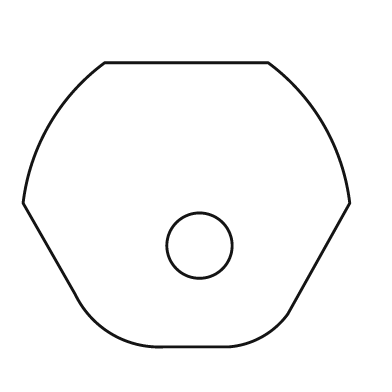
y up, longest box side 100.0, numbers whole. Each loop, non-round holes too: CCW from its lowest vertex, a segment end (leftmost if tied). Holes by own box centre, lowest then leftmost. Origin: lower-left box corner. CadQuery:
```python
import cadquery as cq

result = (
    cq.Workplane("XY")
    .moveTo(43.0, 0.0)
    .lineTo(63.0, 0.0)
    .threePointArc((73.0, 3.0), (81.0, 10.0))
    .lineTo(100.0, 44.0)
    .threePointArc((92.0, 68.0), (75.0, 87.0))
    .lineTo(25.0, 87.0)
    .threePointArc((8.0, 68.0), (0.0, 44.0))
    .lineTo(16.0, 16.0)
    .threePointArc((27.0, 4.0), (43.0, 0.0))
    .close()
    .moveTo(54.0, 31.0)
    .circle(10.0)
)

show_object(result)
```